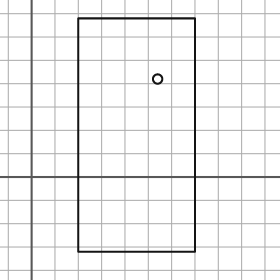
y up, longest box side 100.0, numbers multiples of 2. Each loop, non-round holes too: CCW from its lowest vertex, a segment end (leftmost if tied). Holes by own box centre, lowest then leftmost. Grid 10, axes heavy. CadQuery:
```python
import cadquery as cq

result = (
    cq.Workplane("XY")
    .moveTo(20.0, -32.0)
    .lineTo(70.0, -32.0)
    .lineTo(70.0, 68.0)
    .lineTo(20.0, 68.0)
    .close()
    .moveTo(54.0, 42.0)
    .circle(2.0)
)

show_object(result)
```